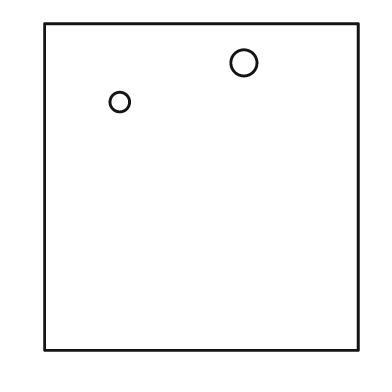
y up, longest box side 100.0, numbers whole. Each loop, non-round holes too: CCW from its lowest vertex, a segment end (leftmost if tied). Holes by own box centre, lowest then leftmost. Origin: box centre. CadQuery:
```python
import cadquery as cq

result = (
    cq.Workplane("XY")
    .moveTo(-48.0, -50.0)
    .lineTo(48.0, -50.0)
    .lineTo(48.0, 50.0)
    .lineTo(-48.0, 50.0)
    .close()
    .moveTo(-25.0, 26.0)
    .circle(3.0)
    .moveTo(13.0, 38.0)
    .circle(4.0)
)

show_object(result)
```